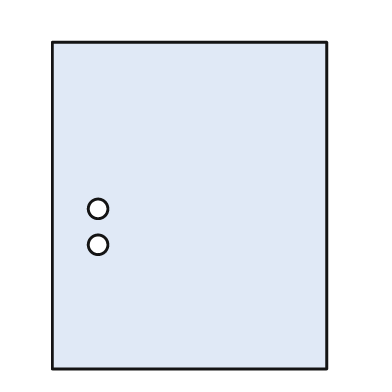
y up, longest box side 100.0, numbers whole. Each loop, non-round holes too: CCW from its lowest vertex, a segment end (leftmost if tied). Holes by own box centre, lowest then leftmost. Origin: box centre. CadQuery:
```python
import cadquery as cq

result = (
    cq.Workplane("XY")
    .moveTo(-42.0, -50.0)
    .lineTo(42.0, -50.0)
    .lineTo(42.0, 50.0)
    .lineTo(-42.0, 50.0)
    .close()
    .moveTo(-28.0, -12.0)
    .circle(3.0)
    .moveTo(-28.0, -1.0)
    .circle(3.0)
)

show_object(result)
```